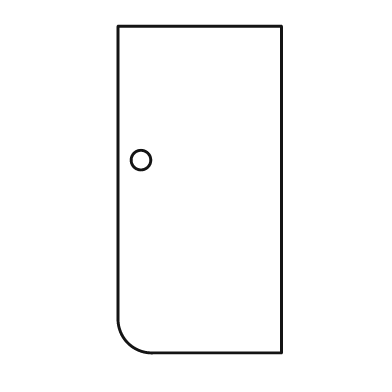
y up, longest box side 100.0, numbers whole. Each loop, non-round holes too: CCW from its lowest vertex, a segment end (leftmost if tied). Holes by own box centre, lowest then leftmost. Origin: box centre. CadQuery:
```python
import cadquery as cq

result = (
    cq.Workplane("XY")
    .moveTo(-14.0, -50.0)
    .lineTo(25.0, -50.0)
    .lineTo(25.0, 50.0)
    .lineTo(-25.0, 50.0)
    .lineTo(-25.0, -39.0)
    .threePointArc((-22.0, -47.0), (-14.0, -50.0))
    .close()
    .moveTo(-18.0, 9.0)
    .circle(3.0)
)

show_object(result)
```